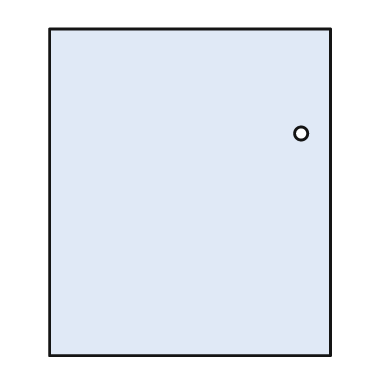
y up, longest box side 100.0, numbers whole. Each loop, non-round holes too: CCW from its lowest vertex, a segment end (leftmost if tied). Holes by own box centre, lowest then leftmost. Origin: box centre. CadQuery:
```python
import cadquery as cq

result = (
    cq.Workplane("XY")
    .moveTo(-43.0, -50.0)
    .lineTo(43.0, -50.0)
    .lineTo(43.0, 50.0)
    .lineTo(-43.0, 50.0)
    .close()
    .moveTo(34.0, 18.0)
    .circle(2.0)
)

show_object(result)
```